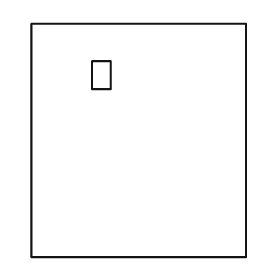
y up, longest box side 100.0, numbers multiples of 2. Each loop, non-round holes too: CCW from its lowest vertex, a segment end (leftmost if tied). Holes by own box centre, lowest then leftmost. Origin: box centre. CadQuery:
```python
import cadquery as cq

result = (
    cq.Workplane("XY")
    .moveTo(-46.0, -50.0)
    .lineTo(46.0, -50.0)
    .lineTo(46.0, 50.0)
    .lineTo(-46.0, 50.0)
    .close()
    .moveTo(-20.0, 22.0)
    .lineTo(-12.0, 22.0)
    .lineTo(-12.0, 34.0)
    .lineTo(-20.0, 34.0)
    .close()
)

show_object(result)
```